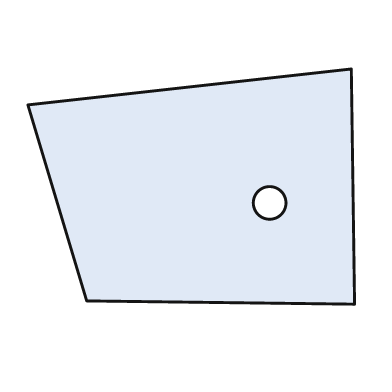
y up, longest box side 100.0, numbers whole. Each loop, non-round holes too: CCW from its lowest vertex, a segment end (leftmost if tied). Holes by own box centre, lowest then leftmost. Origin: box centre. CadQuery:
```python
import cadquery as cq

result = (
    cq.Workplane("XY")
    .moveTo(50.0, -36.0)
    .lineTo(49.0, 36.0)
    .lineTo(-50.0, 25.0)
    .lineTo(-32.0, -35.0)
    .close()
    .moveTo(24.0, -5.0)
    .circle(5.0)
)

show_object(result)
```